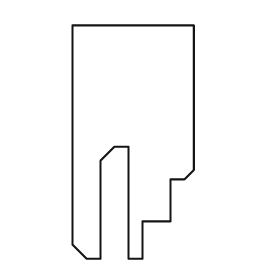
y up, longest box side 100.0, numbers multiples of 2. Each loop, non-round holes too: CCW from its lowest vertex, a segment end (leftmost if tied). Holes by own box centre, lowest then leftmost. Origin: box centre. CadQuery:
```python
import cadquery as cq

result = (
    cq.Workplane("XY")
    .moveTo(-20.0, -50.0)
    .lineTo(-14.0, -50.0)
    .lineTo(-14.0, -8.0)
    .lineTo(-8.0, -2.0)
    .lineTo(-2.0, -2.0)
    .lineTo(-2.0, -50.0)
    .lineTo(4.0, -50.0)
    .lineTo(4.0, -34.0)
    .lineTo(16.0, -34.0)
    .lineTo(16.0, -16.0)
    .lineTo(22.0, -16.0)
    .lineTo(26.0, -12.0)
    .lineTo(26.0, 50.0)
    .lineTo(-26.0, 50.0)
    .lineTo(-26.0, -44.0)
    .close()
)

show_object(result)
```